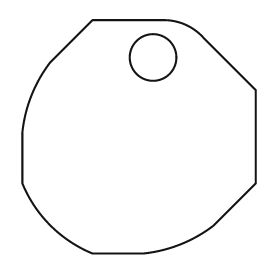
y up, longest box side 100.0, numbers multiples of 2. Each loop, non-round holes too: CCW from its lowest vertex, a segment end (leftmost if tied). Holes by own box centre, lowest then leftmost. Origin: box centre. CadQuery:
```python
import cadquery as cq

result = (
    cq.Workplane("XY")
    .moveTo(-20.0, -50.0)
    .lineTo(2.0, -50.0)
    .threePointArc((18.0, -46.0), (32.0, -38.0))
    .lineTo(50.0, -20.0)
    .lineTo(50.0, 20.0)
    .lineTo(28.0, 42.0)
    .threePointArc((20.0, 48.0), (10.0, 50.0))
    .lineTo(-20.0, 50.0)
    .lineTo(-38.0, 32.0)
    .threePointArc((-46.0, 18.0), (-50.0, 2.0))
    .lineTo(-50.0, -20.0)
    .threePointArc((-38.0, -38.0), (-20.0, -50.0))
    .close()
    .moveTo(6.0, 34.0)
    .circle(10.0)
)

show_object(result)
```